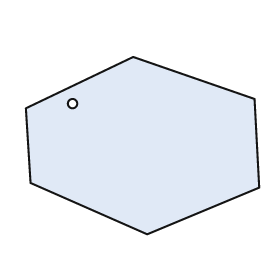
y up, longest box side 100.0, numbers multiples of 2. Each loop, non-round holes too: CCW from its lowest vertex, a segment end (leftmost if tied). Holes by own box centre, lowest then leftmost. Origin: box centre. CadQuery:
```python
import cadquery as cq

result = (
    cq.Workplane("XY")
    .moveTo(2.0, -38.0)
    .lineTo(50.0, -18.0)
    .lineTo(48.0, 20.0)
    .lineTo(-4.0, 38.0)
    .lineTo(-50.0, 16.0)
    .lineTo(-48.0, -16.0)
    .close()
    .moveTo(-30.0, 18.0)
    .circle(2.0)
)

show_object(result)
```